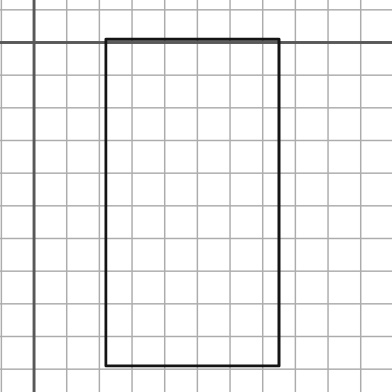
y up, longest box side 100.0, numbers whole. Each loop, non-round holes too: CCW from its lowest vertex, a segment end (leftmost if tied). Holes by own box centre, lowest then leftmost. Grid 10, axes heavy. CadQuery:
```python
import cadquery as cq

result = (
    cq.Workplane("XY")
    .moveTo(22.0, -99.0)
    .lineTo(75.0, -99.0)
    .lineTo(75.0, 1.0)
    .lineTo(22.0, 1.0)
    .close()
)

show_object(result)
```